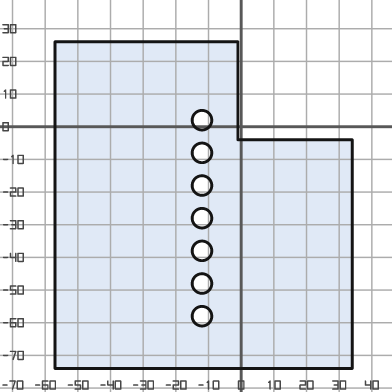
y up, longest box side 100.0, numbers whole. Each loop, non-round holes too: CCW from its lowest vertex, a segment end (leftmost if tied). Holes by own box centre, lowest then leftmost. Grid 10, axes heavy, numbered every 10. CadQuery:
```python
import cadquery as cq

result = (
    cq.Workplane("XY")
    .moveTo(-57.0, -74.0)
    .lineTo(34.0, -74.0)
    .lineTo(34.0, -4.0)
    .lineTo(-1.0, -4.0)
    .lineTo(-1.0, 26.0)
    .lineTo(-57.0, 26.0)
    .close()
    .moveTo(-12.0, -58.0)
    .circle(3.0)
    .moveTo(-12.0, -48.0)
    .circle(3.0)
    .moveTo(-12.0, -38.0)
    .circle(3.0)
    .moveTo(-12.0, -28.0)
    .circle(3.0)
    .moveTo(-12.0, -18.0)
    .circle(3.0)
    .moveTo(-12.0, -8.0)
    .circle(3.0)
    .moveTo(-12.0, 2.0)
    .circle(3.0)
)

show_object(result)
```